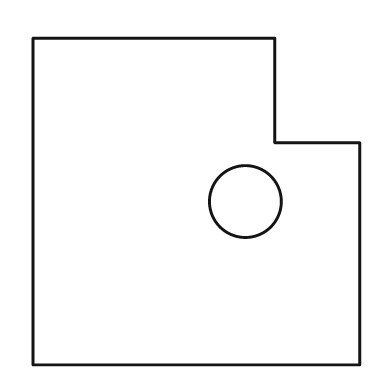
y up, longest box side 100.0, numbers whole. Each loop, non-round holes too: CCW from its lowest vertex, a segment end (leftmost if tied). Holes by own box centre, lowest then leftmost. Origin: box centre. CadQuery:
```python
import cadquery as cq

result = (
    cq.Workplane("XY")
    .moveTo(-50.0, -50.0)
    .lineTo(50.0, -50.0)
    .lineTo(50.0, 18.0)
    .lineTo(24.0, 18.0)
    .lineTo(24.0, 50.0)
    .lineTo(-50.0, 50.0)
    .close()
    .moveTo(15.0, 0.0)
    .circle(11.0)
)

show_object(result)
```